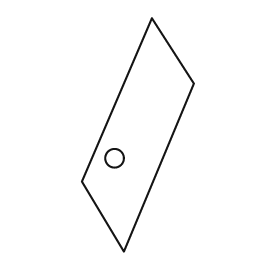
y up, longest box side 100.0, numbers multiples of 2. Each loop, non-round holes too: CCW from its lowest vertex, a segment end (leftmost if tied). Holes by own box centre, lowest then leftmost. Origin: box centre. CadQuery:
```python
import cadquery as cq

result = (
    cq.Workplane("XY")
    .moveTo(-6.0, -50.0)
    .lineTo(24.0, 22.0)
    .lineTo(6.0, 50.0)
    .lineTo(-24.0, -20.0)
    .close()
    .moveTo(-10.0, -10.0)
    .circle(4.0)
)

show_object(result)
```